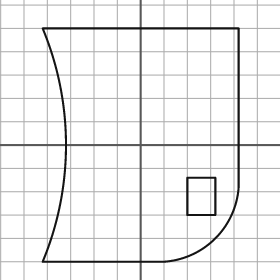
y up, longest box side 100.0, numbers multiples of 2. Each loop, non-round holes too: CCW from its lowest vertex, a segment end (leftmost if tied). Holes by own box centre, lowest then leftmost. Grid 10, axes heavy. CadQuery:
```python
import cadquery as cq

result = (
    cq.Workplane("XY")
    .moveTo(-42.0, -50.0)
    .lineTo(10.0, -50.0)
    .threePointArc((32.0, -40.0), (42.0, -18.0))
    .lineTo(42.0, 50.0)
    .lineTo(-42.0, 50.0)
    .threePointArc((-32.0, 0.0), (-42.0, -50.0))
    .close()
    .moveTo(20.0, -30.0)
    .lineTo(32.0, -30.0)
    .lineTo(32.0, -14.0)
    .lineTo(20.0, -14.0)
    .close()
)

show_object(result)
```